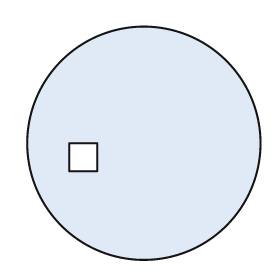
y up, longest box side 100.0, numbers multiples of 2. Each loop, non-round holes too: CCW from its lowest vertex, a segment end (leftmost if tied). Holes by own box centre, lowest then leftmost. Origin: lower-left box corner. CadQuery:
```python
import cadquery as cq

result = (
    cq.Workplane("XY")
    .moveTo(50.0, 50.0)
    .circle(50.0)
    .moveTo(18.0, 38.0)
    .lineTo(30.0, 38.0)
    .lineTo(30.0, 50.0)
    .lineTo(18.0, 50.0)
    .close()
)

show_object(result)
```